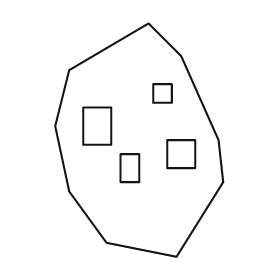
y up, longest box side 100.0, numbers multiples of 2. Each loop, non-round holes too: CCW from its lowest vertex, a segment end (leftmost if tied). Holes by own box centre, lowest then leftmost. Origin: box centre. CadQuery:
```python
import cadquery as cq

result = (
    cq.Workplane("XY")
    .moveTo(16.0, -50.0)
    .lineTo(36.0, -18.0)
    .lineTo(34.0, 0.0)
    .lineTo(18.0, 36.0)
    .lineTo(4.0, 50.0)
    .lineTo(-30.0, 30.0)
    .lineTo(-36.0, 6.0)
    .lineTo(-30.0, -22.0)
    .lineTo(-14.0, -44.0)
    .close()
    .moveTo(-8.0, -18.0)
    .lineTo(0.0, -18.0)
    .lineTo(0.0, -6.0)
    .lineTo(-8.0, -6.0)
    .close()
    .moveTo(12.0, -12.0)
    .lineTo(24.0, -12.0)
    .lineTo(24.0, 0.0)
    .lineTo(12.0, 0.0)
    .close()
    .moveTo(-24.0, -2.0)
    .lineTo(-12.0, -2.0)
    .lineTo(-12.0, 14.0)
    .lineTo(-24.0, 14.0)
    .close()
    .moveTo(6.0, 16.0)
    .lineTo(14.0, 16.0)
    .lineTo(14.0, 24.0)
    .lineTo(6.0, 24.0)
    .close()
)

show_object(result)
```